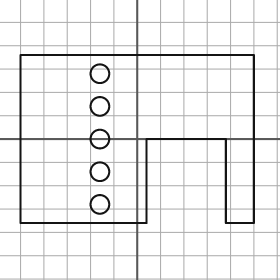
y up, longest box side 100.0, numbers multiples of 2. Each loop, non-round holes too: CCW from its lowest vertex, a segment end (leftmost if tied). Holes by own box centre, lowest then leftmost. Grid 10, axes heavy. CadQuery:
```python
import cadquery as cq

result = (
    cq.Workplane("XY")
    .moveTo(-50.0, -36.0)
    .lineTo(4.0, -36.0)
    .lineTo(4.0, 0.0)
    .lineTo(38.0, 0.0)
    .lineTo(38.0, -36.0)
    .lineTo(50.0, -36.0)
    .lineTo(50.0, 36.0)
    .lineTo(-50.0, 36.0)
    .close()
    .moveTo(-16.0, -28.0)
    .circle(4.0)
    .moveTo(-16.0, -14.0)
    .circle(4.0)
    .moveTo(-16.0, 0.0)
    .circle(4.0)
    .moveTo(-16.0, 14.0)
    .circle(4.0)
    .moveTo(-16.0, 28.0)
    .circle(4.0)
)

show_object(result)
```